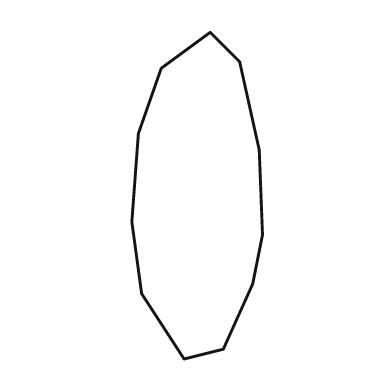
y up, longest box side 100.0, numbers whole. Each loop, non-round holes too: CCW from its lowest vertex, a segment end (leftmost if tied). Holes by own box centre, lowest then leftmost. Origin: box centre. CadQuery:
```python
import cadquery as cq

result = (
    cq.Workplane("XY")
    .moveTo(-4.0, -50.0)
    .lineTo(8.0, -47.0)
    .lineTo(17.0, -27.0)
    .lineTo(20.0, -12.0)
    .lineTo(19.0, 14.0)
    .lineTo(13.0, 41.0)
    .lineTo(4.0, 50.0)
    .lineTo(-11.0, 39.0)
    .lineTo(-18.0, 19.0)
    .lineTo(-20.0, -8.0)
    .lineTo(-17.0, -30.0)
    .close()
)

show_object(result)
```